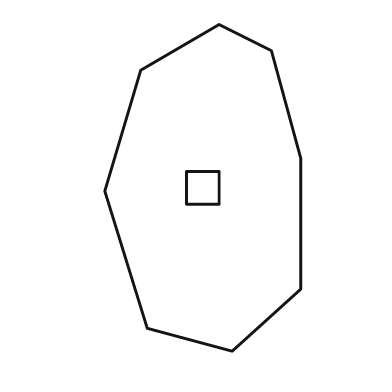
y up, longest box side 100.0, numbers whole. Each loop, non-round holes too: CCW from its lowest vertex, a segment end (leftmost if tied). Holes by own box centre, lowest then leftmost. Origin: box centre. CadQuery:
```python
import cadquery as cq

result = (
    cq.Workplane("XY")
    .moveTo(9.0, -50.0)
    .lineTo(30.0, -31.0)
    .lineTo(30.0, 9.0)
    .lineTo(21.0, 42.0)
    .lineTo(5.0, 50.0)
    .lineTo(-19.0, 36.0)
    .lineTo(-30.0, -1.0)
    .lineTo(-17.0, -43.0)
    .close()
    .moveTo(-5.0, -5.0)
    .lineTo(5.0, -5.0)
    .lineTo(5.0, 5.0)
    .lineTo(-5.0, 5.0)
    .close()
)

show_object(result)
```